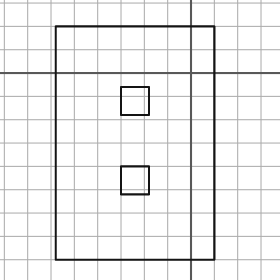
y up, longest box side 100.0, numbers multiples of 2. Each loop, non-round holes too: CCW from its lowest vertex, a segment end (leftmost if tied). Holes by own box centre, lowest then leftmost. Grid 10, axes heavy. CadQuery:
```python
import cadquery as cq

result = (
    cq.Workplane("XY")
    .moveTo(-58.0, -80.0)
    .lineTo(10.0, -80.0)
    .lineTo(10.0, 20.0)
    .lineTo(-58.0, 20.0)
    .close()
    .moveTo(-30.0, -52.0)
    .lineTo(-18.0, -52.0)
    .lineTo(-18.0, -40.0)
    .lineTo(-30.0, -40.0)
    .close()
    .moveTo(-30.0, -18.0)
    .lineTo(-18.0, -18.0)
    .lineTo(-18.0, -6.0)
    .lineTo(-30.0, -6.0)
    .close()
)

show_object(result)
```